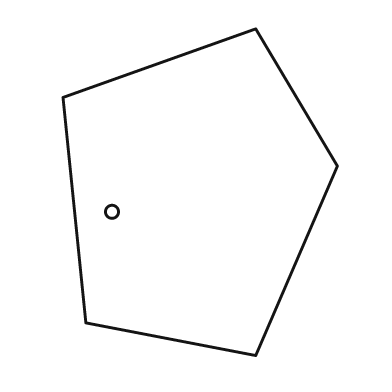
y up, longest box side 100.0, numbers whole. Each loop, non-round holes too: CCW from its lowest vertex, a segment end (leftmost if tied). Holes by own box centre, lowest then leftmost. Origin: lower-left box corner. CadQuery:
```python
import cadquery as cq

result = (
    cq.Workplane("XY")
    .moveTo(59.0, 0.0)
    .lineTo(84.0, 58.0)
    .lineTo(59.0, 100.0)
    .lineTo(0.0, 79.0)
    .lineTo(7.0, 10.0)
    .close()
    .moveTo(15.0, 44.0)
    .circle(2.0)
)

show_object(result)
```